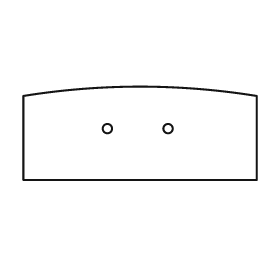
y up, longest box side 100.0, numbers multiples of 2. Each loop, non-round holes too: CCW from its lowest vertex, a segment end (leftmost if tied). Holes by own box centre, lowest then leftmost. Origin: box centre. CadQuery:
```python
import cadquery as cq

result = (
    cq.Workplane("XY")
    .moveTo(-50.0, -20.0)
    .lineTo(50.0, -20.0)
    .lineTo(50.0, 16.0)
    .threePointArc((0.0, 20.0), (-50.0, 16.0))
    .close()
    .moveTo(-14.0, 2.0)
    .circle(2.0)
    .moveTo(12.0, 2.0)
    .circle(2.0)
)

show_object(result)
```